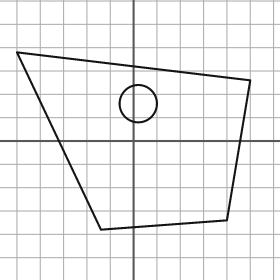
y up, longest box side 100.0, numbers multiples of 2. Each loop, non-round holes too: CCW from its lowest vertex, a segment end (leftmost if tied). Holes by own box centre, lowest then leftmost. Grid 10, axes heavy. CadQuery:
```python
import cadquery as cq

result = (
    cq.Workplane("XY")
    .moveTo(-14.0, -38.0)
    .lineTo(40.0, -34.0)
    .lineTo(50.0, 26.0)
    .lineTo(-50.0, 38.0)
    .close()
    .moveTo(2.0, 16.0)
    .circle(8.0)
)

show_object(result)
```